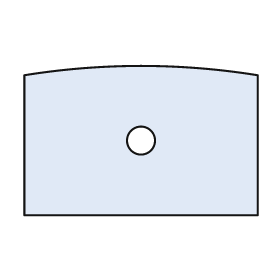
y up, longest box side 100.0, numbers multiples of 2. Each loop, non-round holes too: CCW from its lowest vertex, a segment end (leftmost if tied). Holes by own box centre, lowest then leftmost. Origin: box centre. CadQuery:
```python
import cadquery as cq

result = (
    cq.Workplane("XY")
    .moveTo(-50.0, -32.0)
    .lineTo(50.0, -32.0)
    .lineTo(50.0, 28.0)
    .threePointArc((0.0, 32.0), (-50.0, 28.0))
    .close()
    .moveTo(0.0, 0.0)
    .circle(6.0)
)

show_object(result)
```